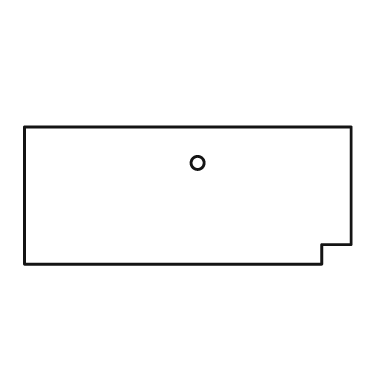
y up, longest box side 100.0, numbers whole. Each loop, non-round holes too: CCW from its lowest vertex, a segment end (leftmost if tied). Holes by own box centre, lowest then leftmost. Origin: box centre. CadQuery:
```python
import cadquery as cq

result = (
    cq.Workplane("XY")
    .moveTo(-50.0, -21.0)
    .lineTo(41.0, -21.0)
    .lineTo(41.0, -15.0)
    .lineTo(50.0, -15.0)
    .lineTo(50.0, 21.0)
    .lineTo(-50.0, 21.0)
    .close()
    .moveTo(3.0, 10.0)
    .circle(2.0)
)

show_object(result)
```